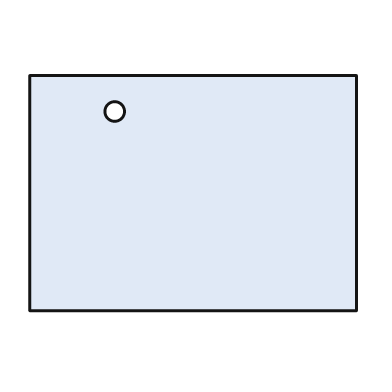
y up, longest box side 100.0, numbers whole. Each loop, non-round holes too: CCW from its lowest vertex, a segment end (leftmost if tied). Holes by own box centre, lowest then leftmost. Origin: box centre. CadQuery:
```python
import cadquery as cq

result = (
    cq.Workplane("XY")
    .moveTo(-50.0, -36.0)
    .lineTo(50.0, -36.0)
    .lineTo(50.0, 36.0)
    .lineTo(-50.0, 36.0)
    .close()
    .moveTo(-24.0, 25.0)
    .circle(3.0)
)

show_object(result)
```